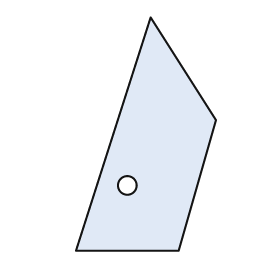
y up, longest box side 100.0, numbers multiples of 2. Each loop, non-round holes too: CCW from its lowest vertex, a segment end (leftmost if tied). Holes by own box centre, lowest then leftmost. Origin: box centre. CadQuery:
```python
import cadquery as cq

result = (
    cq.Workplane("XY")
    .moveTo(-30.0, -50.0)
    .lineTo(14.0, -50.0)
    .lineTo(30.0, 6.0)
    .lineTo(2.0, 50.0)
    .close()
    .moveTo(-8.0, -22.0)
    .circle(4.0)
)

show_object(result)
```